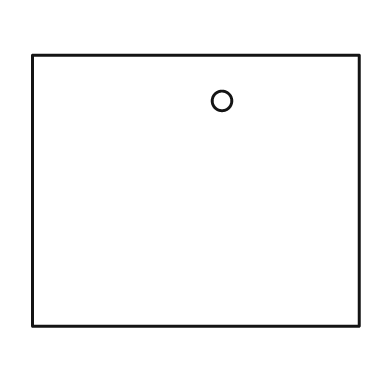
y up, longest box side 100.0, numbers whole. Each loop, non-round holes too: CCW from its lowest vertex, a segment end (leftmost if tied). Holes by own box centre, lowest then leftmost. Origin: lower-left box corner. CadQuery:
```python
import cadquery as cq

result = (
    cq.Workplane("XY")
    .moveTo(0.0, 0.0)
    .lineTo(100.0, 0.0)
    .lineTo(100.0, 83.0)
    .lineTo(0.0, 83.0)
    .close()
    .moveTo(58.0, 69.0)
    .circle(3.0)
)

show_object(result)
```